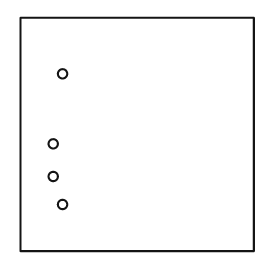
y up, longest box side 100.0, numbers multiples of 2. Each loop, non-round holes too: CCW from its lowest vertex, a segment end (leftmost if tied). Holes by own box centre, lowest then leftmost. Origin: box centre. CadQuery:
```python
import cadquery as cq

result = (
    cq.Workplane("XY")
    .moveTo(-50.0, -50.0)
    .lineTo(50.0, -50.0)
    .lineTo(50.0, 50.0)
    .lineTo(-50.0, 50.0)
    .close()
    .moveTo(-32.0, -30.0)
    .circle(2.0)
    .moveTo(-36.0, -18.0)
    .circle(2.0)
    .moveTo(-36.0, -4.0)
    .circle(2.0)
    .moveTo(-32.0, 26.0)
    .circle(2.0)
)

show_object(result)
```